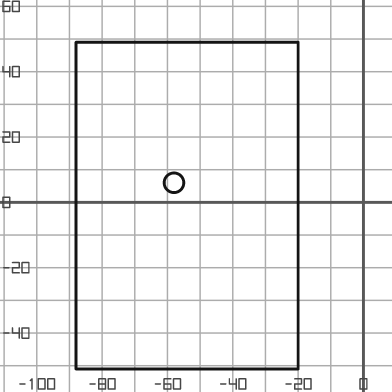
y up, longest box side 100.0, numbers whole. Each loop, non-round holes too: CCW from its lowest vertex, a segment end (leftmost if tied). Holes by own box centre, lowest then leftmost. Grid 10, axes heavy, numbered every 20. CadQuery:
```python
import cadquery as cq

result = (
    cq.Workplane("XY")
    .moveTo(-88.0, -51.0)
    .lineTo(-20.0, -51.0)
    .lineTo(-20.0, 49.0)
    .lineTo(-88.0, 49.0)
    .close()
    .moveTo(-58.0, 6.0)
    .circle(3.0)
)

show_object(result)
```